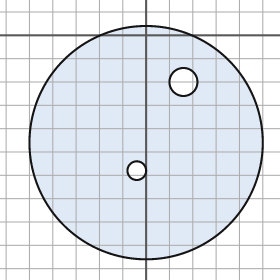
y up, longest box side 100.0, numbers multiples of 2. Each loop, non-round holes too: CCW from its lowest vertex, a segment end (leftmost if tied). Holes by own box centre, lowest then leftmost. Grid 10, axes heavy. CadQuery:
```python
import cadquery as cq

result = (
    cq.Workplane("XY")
    .moveTo(0.0, -46.0)
    .circle(50.0)
    .moveTo(-4.0, -58.0)
    .circle(4.0)
    .moveTo(16.0, -20.0)
    .circle(6.0)
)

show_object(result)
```